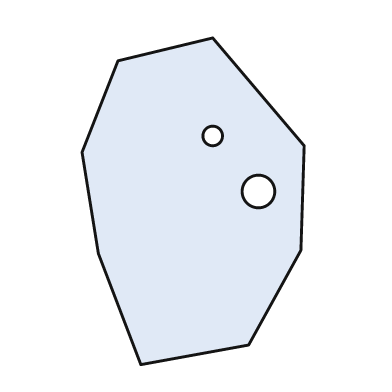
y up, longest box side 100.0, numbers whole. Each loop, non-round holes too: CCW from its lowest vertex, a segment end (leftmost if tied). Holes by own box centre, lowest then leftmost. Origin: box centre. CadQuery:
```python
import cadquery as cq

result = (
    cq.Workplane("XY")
    .moveTo(-16.0, -50.0)
    .lineTo(17.0, -44.0)
    .lineTo(33.0, -15.0)
    .lineTo(34.0, 17.0)
    .lineTo(6.0, 50.0)
    .lineTo(-23.0, 43.0)
    .lineTo(-34.0, 15.0)
    .lineTo(-29.0, -16.0)
    .close()
    .moveTo(20.0, 3.0)
    .circle(5.0)
    .moveTo(6.0, 20.0)
    .circle(3.0)
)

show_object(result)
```